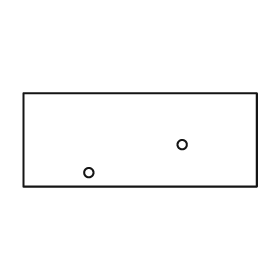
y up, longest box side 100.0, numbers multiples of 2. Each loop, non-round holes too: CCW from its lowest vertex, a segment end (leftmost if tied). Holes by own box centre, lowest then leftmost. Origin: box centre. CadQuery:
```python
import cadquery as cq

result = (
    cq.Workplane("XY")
    .moveTo(-50.0, -20.0)
    .lineTo(50.0, -20.0)
    .lineTo(50.0, 20.0)
    .lineTo(-50.0, 20.0)
    .close()
    .moveTo(-22.0, -14.0)
    .circle(2.0)
    .moveTo(18.0, -2.0)
    .circle(2.0)
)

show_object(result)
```